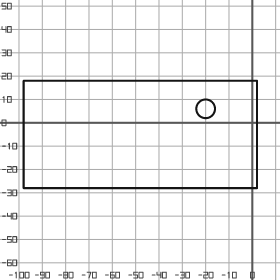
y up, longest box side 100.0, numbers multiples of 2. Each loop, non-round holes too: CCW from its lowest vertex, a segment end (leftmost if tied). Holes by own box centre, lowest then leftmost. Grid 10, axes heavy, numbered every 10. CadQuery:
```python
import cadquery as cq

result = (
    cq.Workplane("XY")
    .moveTo(-98.0, -28.0)
    .lineTo(2.0, -28.0)
    .lineTo(2.0, 18.0)
    .lineTo(-98.0, 18.0)
    .close()
    .moveTo(-20.0, 6.0)
    .circle(4.0)
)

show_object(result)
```